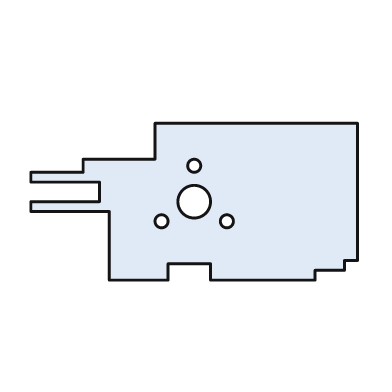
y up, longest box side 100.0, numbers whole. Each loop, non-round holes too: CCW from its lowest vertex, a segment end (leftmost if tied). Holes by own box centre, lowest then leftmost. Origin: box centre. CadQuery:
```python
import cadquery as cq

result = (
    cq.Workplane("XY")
    .moveTo(-26.0, -24.0)
    .lineTo(-8.0, -24.0)
    .lineTo(-8.0, -19.0)
    .lineTo(5.0, -19.0)
    .lineTo(5.0, -24.0)
    .lineTo(37.0, -24.0)
    .lineTo(37.0, -21.0)
    .lineTo(46.0, -21.0)
    .lineTo(46.0, -18.0)
    .lineTo(50.0, -18.0)
    .lineTo(50.0, 24.0)
    .lineTo(-12.0, 24.0)
    .lineTo(-12.0, 13.0)
    .lineTo(-34.0, 13.0)
    .lineTo(-34.0, 9.0)
    .lineTo(-50.0, 9.0)
    .lineTo(-50.0, 6.0)
    .lineTo(-29.0, 6.0)
    .lineTo(-29.0, 0.0)
    .lineTo(-50.0, 0.0)
    .lineTo(-50.0, -3.0)
    .lineTo(-26.0, -3.0)
    .close()
    .moveTo(-10.0, -6.0)
    .circle(2.0)
    .moveTo(10.0, -6.0)
    .circle(2.0)
    .moveTo(0.0, 0.0)
    .circle(5.0)
    .moveTo(0.0, 11.0)
    .circle(2.0)
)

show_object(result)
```